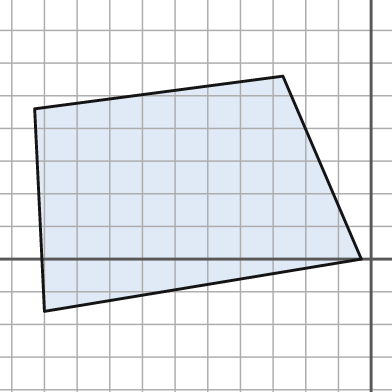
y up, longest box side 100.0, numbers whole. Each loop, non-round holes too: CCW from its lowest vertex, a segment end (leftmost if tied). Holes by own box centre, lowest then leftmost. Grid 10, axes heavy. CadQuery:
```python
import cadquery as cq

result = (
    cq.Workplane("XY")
    .moveTo(-100.0, -16.0)
    .lineTo(-3.0, 0.0)
    .lineTo(-27.0, 56.0)
    .lineTo(-103.0, 46.0)
    .close()
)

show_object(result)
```